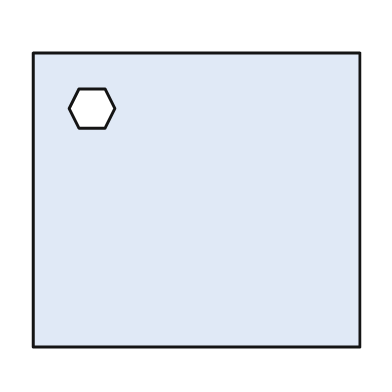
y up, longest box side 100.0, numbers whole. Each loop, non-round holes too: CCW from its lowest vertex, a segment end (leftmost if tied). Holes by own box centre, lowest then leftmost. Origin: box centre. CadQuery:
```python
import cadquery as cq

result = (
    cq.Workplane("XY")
    .moveTo(-50.0, -45.0)
    .lineTo(50.0, -45.0)
    .lineTo(50.0, 45.0)
    .lineTo(-50.0, 45.0)
    .close()
    .moveTo(-36.0, 22.0)
    .lineTo(-28.0, 22.0)
    .lineTo(-25.0, 28.0)
    .lineTo(-28.0, 34.0)
    .lineTo(-36.0, 34.0)
    .lineTo(-39.0, 28.0)
    .close()
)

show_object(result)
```